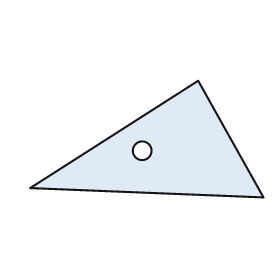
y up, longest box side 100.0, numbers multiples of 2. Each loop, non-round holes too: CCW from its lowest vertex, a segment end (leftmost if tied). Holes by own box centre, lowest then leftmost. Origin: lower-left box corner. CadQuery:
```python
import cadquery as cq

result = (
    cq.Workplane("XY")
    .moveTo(100.0, 0.0)
    .lineTo(72.0, 50.0)
    .lineTo(0.0, 4.0)
    .close()
    .moveTo(48.0, 20.0)
    .circle(4.0)
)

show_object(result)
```